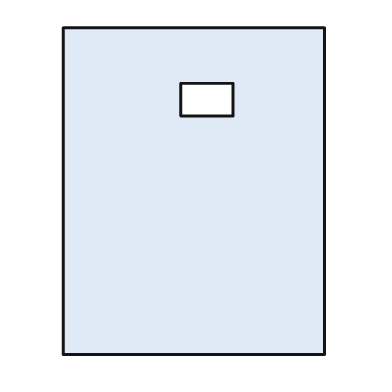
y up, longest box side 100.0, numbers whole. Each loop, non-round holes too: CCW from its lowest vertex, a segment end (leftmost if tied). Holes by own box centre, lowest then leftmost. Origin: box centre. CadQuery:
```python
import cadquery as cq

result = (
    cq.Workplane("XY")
    .moveTo(-40.0, -50.0)
    .lineTo(40.0, -50.0)
    .lineTo(40.0, 50.0)
    .lineTo(-40.0, 50.0)
    .close()
    .moveTo(-4.0, 23.0)
    .lineTo(12.0, 23.0)
    .lineTo(12.0, 33.0)
    .lineTo(-4.0, 33.0)
    .close()
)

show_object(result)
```